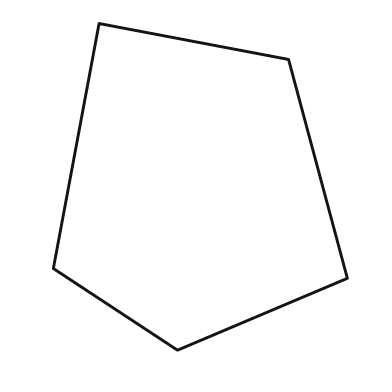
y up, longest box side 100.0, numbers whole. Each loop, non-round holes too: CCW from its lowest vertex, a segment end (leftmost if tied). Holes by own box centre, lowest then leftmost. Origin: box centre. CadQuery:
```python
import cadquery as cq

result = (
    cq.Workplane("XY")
    .moveTo(-7.0, -50.0)
    .lineTo(45.0, -28.0)
    .lineTo(27.0, 39.0)
    .lineTo(-31.0, 50.0)
    .lineTo(-45.0, -25.0)
    .close()
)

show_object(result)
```